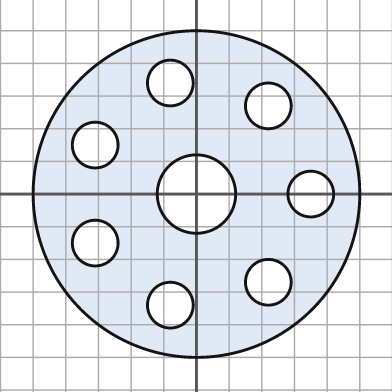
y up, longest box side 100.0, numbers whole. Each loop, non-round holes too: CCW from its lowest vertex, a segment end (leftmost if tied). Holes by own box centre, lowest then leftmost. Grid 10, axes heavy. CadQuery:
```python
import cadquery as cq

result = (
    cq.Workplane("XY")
    .moveTo(0.0, 0.0)
    .circle(50.0)
    .moveTo(-8.0, -34.0)
    .circle(7.0)
    .moveTo(22.0, -27.0)
    .circle(7.0)
    .moveTo(-31.0, -15.0)
    .circle(7.0)
    .moveTo(0.0, 0.0)
    .circle(12.0)
    .moveTo(35.0, 0.0)
    .circle(7.0)
    .moveTo(-31.0, 15.0)
    .circle(7.0)
    .moveTo(22.0, 27.0)
    .circle(7.0)
    .moveTo(-8.0, 34.0)
    .circle(7.0)
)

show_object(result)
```